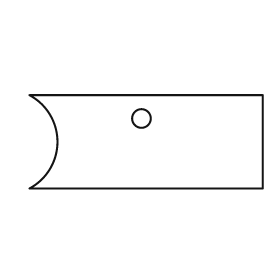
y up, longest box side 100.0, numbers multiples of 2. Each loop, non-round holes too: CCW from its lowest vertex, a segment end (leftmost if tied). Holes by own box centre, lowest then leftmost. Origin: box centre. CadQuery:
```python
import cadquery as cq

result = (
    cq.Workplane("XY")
    .moveTo(-50.0, -20.0)
    .lineTo(50.0, -20.0)
    .lineTo(50.0, 20.0)
    .lineTo(-50.0, 20.0)
    .threePointArc((-38.0, 0.0), (-50.0, -20.0))
    .close()
    .moveTo(-2.0, 10.0)
    .circle(4.0)
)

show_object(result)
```